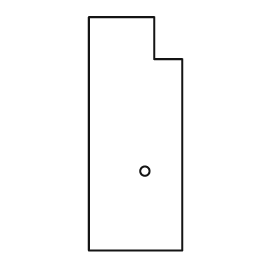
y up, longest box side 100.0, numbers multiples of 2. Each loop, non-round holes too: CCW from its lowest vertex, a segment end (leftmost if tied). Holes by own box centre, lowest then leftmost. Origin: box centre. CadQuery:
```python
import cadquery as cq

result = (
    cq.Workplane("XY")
    .moveTo(-20.0, -50.0)
    .lineTo(20.0, -50.0)
    .lineTo(20.0, 32.0)
    .lineTo(8.0, 32.0)
    .lineTo(8.0, 50.0)
    .lineTo(-20.0, 50.0)
    .close()
    .moveTo(4.0, -16.0)
    .circle(2.0)
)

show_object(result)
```